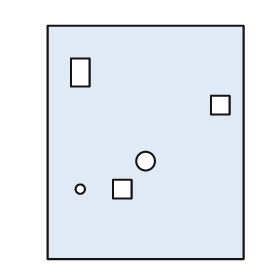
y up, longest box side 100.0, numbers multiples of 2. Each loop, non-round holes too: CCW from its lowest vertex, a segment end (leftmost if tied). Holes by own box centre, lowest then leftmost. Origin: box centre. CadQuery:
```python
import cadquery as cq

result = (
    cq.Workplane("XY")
    .moveTo(-42.0, -50.0)
    .lineTo(42.0, -50.0)
    .lineTo(42.0, 50.0)
    .lineTo(-42.0, 50.0)
    .close()
    .moveTo(-28.0, -20.0)
    .circle(2.0)
    .moveTo(-14.0, -24.0)
    .lineTo(-6.0, -24.0)
    .lineTo(-6.0, -16.0)
    .lineTo(-14.0, -16.0)
    .close()
    .moveTo(0.0, -8.0)
    .circle(4.0)
    .moveTo(28.0, 12.0)
    .lineTo(36.0, 12.0)
    .lineTo(36.0, 20.0)
    .lineTo(28.0, 20.0)
    .close()
    .moveTo(-32.0, 24.0)
    .lineTo(-24.0, 24.0)
    .lineTo(-24.0, 36.0)
    .lineTo(-32.0, 36.0)
    .close()
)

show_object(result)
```